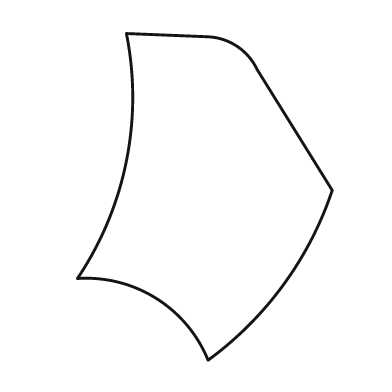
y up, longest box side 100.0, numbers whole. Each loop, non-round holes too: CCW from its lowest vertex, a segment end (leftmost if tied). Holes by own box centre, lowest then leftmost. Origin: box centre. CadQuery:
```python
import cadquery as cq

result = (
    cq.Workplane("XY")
    .moveTo(1.0, -50.0)
    .threePointArc((24.0, -27.0), (39.0, 2.0))
    .lineTo(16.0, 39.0)
    .threePointArc((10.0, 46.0), (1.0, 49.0))
    .lineTo(-24.0, 50.0)
    .threePointArc((-24.0, 11.0), (-39.0, -25.0))
    .threePointArc((-15.0, -31.0), (1.0, -50.0))
    .close()
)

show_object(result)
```